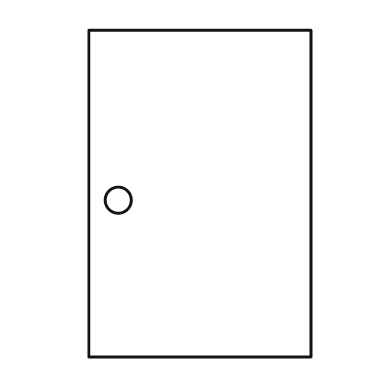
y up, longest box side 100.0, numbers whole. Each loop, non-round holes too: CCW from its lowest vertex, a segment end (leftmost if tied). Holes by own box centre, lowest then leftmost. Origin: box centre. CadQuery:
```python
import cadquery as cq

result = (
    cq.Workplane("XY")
    .moveTo(-34.0, -50.0)
    .lineTo(34.0, -50.0)
    .lineTo(34.0, 50.0)
    .lineTo(-34.0, 50.0)
    .close()
    .moveTo(-25.0, -2.0)
    .circle(4.0)
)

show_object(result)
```